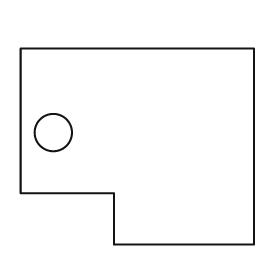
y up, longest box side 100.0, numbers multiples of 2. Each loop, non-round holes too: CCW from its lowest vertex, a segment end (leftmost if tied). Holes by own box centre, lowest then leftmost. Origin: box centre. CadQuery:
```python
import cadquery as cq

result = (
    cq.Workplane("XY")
    .moveTo(-10.0, -42.0)
    .lineTo(50.0, -42.0)
    .lineTo(50.0, 42.0)
    .lineTo(-50.0, 42.0)
    .lineTo(-50.0, -20.0)
    .lineTo(-10.0, -20.0)
    .close()
    .moveTo(-36.0, 6.0)
    .circle(8.0)
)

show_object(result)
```